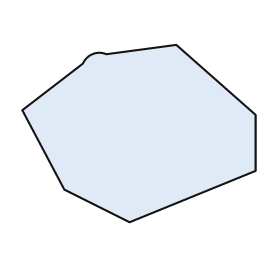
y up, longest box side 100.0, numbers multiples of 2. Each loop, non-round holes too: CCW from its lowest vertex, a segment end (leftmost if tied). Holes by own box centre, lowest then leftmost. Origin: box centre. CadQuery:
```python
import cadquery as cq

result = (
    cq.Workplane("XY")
    .moveTo(-4.0, -38.0)
    .lineTo(50.0, -16.0)
    .lineTo(50.0, 8.0)
    .lineTo(16.0, 38.0)
    .lineTo(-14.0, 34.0)
    .threePointArc((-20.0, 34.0), (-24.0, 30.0))
    .lineTo(-50.0, 10.0)
    .lineTo(-32.0, -24.0)
    .close()
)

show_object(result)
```